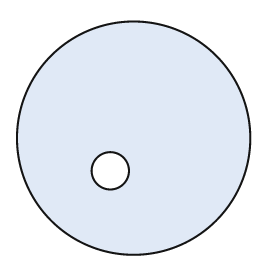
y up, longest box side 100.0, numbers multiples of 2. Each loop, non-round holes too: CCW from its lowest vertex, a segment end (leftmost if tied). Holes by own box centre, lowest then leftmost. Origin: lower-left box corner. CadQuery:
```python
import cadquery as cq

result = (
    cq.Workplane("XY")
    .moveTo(50.0, 50.0)
    .circle(50.0)
    .moveTo(40.0, 36.0)
    .circle(8.0)
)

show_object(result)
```